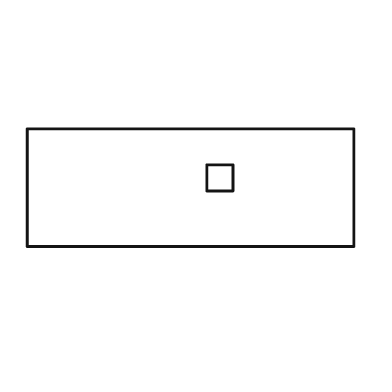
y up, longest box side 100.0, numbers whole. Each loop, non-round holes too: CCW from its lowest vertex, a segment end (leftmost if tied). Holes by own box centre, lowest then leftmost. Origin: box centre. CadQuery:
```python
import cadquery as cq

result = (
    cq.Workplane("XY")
    .moveTo(-50.0, -18.0)
    .lineTo(50.0, -18.0)
    .lineTo(50.0, 18.0)
    .lineTo(-50.0, 18.0)
    .close()
    .moveTo(5.0, -1.0)
    .lineTo(13.0, -1.0)
    .lineTo(13.0, 7.0)
    .lineTo(5.0, 7.0)
    .close()
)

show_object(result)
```